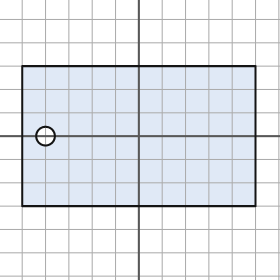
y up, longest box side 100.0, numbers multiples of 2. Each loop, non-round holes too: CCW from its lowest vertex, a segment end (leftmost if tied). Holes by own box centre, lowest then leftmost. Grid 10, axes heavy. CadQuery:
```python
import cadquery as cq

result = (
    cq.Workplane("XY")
    .moveTo(-50.0, -30.0)
    .lineTo(50.0, -30.0)
    .lineTo(50.0, 30.0)
    .lineTo(-50.0, 30.0)
    .close()
    .moveTo(-40.0, 0.0)
    .circle(4.0)
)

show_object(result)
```